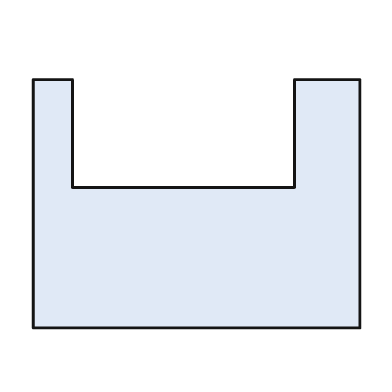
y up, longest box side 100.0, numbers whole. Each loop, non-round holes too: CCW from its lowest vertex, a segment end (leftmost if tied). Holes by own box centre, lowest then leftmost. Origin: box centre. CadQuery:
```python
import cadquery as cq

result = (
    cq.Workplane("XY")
    .moveTo(-50.0, -38.0)
    .lineTo(50.0, -38.0)
    .lineTo(50.0, 38.0)
    .lineTo(30.0, 38.0)
    .lineTo(30.0, 5.0)
    .lineTo(-38.0, 5.0)
    .lineTo(-38.0, 38.0)
    .lineTo(-50.0, 38.0)
    .close()
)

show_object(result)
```